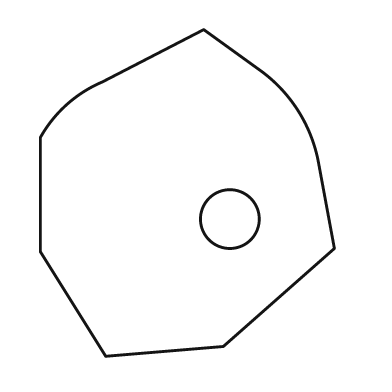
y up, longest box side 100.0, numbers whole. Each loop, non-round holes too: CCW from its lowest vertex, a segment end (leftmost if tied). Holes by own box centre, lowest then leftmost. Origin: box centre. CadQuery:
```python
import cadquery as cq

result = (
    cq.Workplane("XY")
    .moveTo(-25.0, -50.0)
    .lineTo(11.0, -47.0)
    .lineTo(45.0, -17.0)
    .lineTo(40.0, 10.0)
    .threePointArc((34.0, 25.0), (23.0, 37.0))
    .lineTo(5.0, 50.0)
    .lineTo(-26.0, 34.0)
    .threePointArc((-37.0, 27.0), (-45.0, 17.0))
    .lineTo(-45.0, -18.0)
    .close()
    .moveTo(13.0, -8.0)
    .circle(9.0)
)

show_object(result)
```